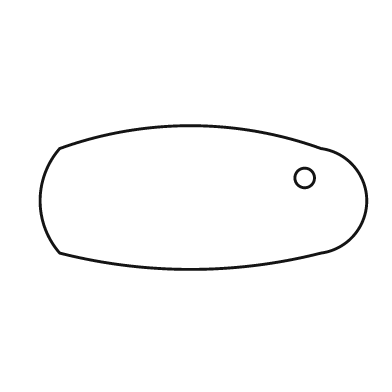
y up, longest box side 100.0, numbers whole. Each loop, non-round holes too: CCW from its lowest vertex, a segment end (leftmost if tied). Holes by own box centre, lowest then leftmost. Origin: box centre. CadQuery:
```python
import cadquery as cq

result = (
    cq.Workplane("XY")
    .moveTo(-44.0, -17.0)
    .threePointArc((-4.0, -22.0), (36.0, -17.0))
    .threePointArc((50.0, -1.0), (36.0, 15.0))
    .threePointArc((-4.0, 22.0), (-44.0, 15.0))
    .threePointArc((-50.0, -1.0), (-44.0, -17.0))
    .close()
    .moveTo(31.0, 6.0)
    .circle(3.0)
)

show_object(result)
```